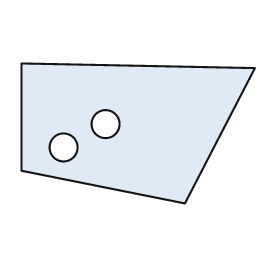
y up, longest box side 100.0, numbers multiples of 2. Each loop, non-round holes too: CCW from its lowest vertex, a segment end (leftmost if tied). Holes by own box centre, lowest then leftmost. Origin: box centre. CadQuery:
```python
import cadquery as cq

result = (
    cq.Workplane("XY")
    .moveTo(20.0, -30.0)
    .lineTo(50.0, 28.0)
    .lineTo(-50.0, 30.0)
    .lineTo(-50.0, -16.0)
    .close()
    .moveTo(-32.0, -6.0)
    .circle(6.0)
    .moveTo(-14.0, 4.0)
    .circle(6.0)
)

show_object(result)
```